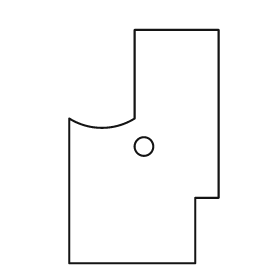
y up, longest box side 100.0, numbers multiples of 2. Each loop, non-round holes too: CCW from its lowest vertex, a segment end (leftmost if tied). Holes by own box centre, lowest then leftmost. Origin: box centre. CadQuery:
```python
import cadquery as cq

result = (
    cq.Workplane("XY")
    .moveTo(-32.0, -50.0)
    .lineTo(22.0, -50.0)
    .lineTo(22.0, -22.0)
    .lineTo(32.0, -22.0)
    .lineTo(32.0, 50.0)
    .lineTo(-4.0, 50.0)
    .lineTo(-4.0, 12.0)
    .threePointArc((-18.0, 8.0), (-32.0, 12.0))
    .close()
    .moveTo(0.0, 0.0)
    .circle(4.0)
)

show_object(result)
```